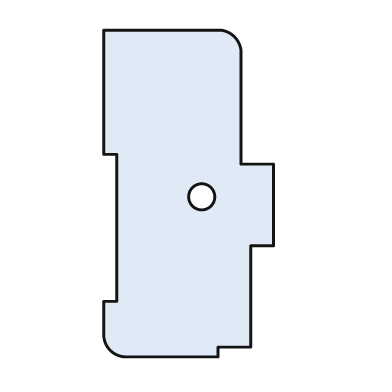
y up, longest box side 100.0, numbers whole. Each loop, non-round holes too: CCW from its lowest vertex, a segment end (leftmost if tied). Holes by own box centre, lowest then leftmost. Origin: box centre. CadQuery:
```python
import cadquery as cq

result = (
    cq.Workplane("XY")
    .moveTo(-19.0, -50.0)
    .lineTo(9.0, -50.0)
    .lineTo(9.0, -47.0)
    .lineTo(19.0, -47.0)
    .lineTo(19.0, -16.0)
    .lineTo(26.0, -16.0)
    .lineTo(26.0, 9.0)
    .lineTo(16.0, 9.0)
    .lineTo(16.0, 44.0)
    .threePointArc((14.0, 48.0), (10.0, 50.0))
    .lineTo(-26.0, 50.0)
    .lineTo(-26.0, 12.0)
    .lineTo(-22.0, 12.0)
    .lineTo(-22.0, -33.0)
    .lineTo(-26.0, -33.0)
    .lineTo(-26.0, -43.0)
    .threePointArc((-24.0, -48.0), (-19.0, -50.0))
    .close()
    .moveTo(4.0, -1.0)
    .circle(4.0)
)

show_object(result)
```